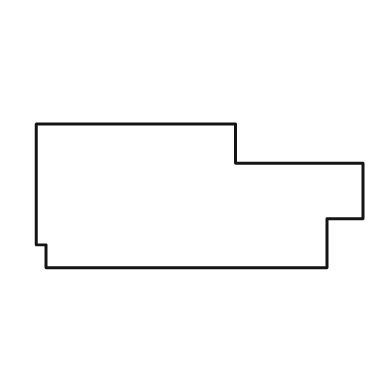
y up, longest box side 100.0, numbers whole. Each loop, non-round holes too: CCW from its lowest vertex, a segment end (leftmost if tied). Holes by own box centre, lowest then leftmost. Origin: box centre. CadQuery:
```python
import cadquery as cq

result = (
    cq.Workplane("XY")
    .moveTo(-47.0, -22.0)
    .lineTo(39.0, -22.0)
    .lineTo(39.0, -7.0)
    .lineTo(50.0, -7.0)
    .lineTo(50.0, 10.0)
    .lineTo(11.0, 10.0)
    .lineTo(11.0, 22.0)
    .lineTo(-50.0, 22.0)
    .lineTo(-50.0, -15.0)
    .lineTo(-47.0, -15.0)
    .close()
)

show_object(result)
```